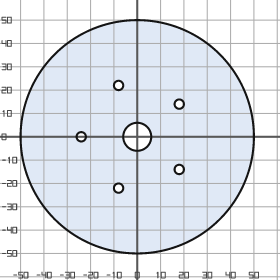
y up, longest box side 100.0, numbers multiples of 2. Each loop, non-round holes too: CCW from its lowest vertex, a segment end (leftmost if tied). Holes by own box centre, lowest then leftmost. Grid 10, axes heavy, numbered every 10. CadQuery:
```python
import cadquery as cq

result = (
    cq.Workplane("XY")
    .moveTo(0.0, 0.0)
    .circle(50.0)
    .moveTo(-8.0, -22.0)
    .circle(2.0)
    .moveTo(18.0, -14.0)
    .circle(2.0)
    .moveTo(-24.0, 0.0)
    .circle(2.0)
    .moveTo(0.0, 0.0)
    .circle(6.0)
    .moveTo(18.0, 14.0)
    .circle(2.0)
    .moveTo(-8.0, 22.0)
    .circle(2.0)
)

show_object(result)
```